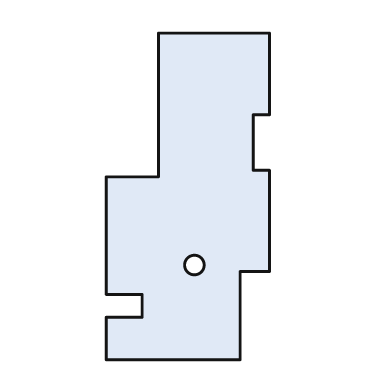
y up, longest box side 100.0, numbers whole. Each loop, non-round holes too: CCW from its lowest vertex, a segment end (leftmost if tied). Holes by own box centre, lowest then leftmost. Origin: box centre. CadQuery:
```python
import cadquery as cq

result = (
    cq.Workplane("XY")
    .moveTo(-25.0, -50.0)
    .lineTo(16.0, -50.0)
    .lineTo(16.0, -23.0)
    .lineTo(25.0, -23.0)
    .lineTo(25.0, 8.0)
    .lineTo(20.0, 8.0)
    .lineTo(20.0, 25.0)
    .lineTo(25.0, 25.0)
    .lineTo(25.0, 50.0)
    .lineTo(-9.0, 50.0)
    .lineTo(-9.0, 6.0)
    .lineTo(-25.0, 6.0)
    .lineTo(-25.0, -30.0)
    .lineTo(-14.0, -30.0)
    .lineTo(-14.0, -37.0)
    .lineTo(-25.0, -37.0)
    .close()
    .moveTo(2.0, -21.0)
    .circle(3.0)
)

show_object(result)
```